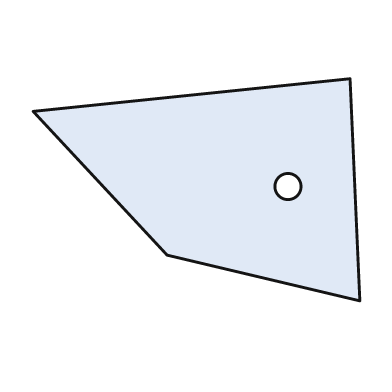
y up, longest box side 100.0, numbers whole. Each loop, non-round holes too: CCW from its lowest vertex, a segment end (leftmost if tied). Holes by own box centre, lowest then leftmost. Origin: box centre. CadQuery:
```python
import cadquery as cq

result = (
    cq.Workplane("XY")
    .moveTo(50.0, -34.0)
    .lineTo(47.0, 34.0)
    .lineTo(-50.0, 24.0)
    .lineTo(-9.0, -20.0)
    .close()
    .moveTo(28.0, 1.0)
    .circle(4.0)
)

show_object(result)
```